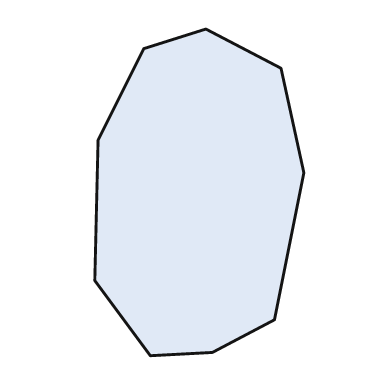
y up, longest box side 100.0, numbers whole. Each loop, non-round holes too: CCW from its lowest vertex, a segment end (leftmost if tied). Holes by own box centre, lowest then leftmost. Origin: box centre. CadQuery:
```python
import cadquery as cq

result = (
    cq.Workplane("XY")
    .moveTo(-15.0, -50.0)
    .lineTo(4.0, -49.0)
    .lineTo(23.0, -39.0)
    .lineTo(32.0, 6.0)
    .lineTo(25.0, 38.0)
    .lineTo(2.0, 50.0)
    .lineTo(-17.0, 44.0)
    .lineTo(-31.0, 16.0)
    .lineTo(-32.0, -27.0)
    .close()
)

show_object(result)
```